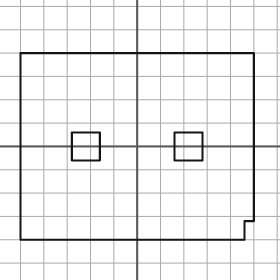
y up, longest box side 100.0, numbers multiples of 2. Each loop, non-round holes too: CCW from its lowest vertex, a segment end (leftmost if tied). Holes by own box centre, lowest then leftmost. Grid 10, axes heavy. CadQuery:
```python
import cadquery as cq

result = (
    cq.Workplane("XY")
    .moveTo(-50.0, -40.0)
    .lineTo(46.0, -40.0)
    .lineTo(46.0, -32.0)
    .lineTo(50.0, -32.0)
    .lineTo(50.0, 40.0)
    .lineTo(-50.0, 40.0)
    .close()
    .moveTo(-28.0, -6.0)
    .lineTo(-16.0, -6.0)
    .lineTo(-16.0, 6.0)
    .lineTo(-28.0, 6.0)
    .close()
    .moveTo(16.0, -6.0)
    .lineTo(28.0, -6.0)
    .lineTo(28.0, 6.0)
    .lineTo(16.0, 6.0)
    .close()
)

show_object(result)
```